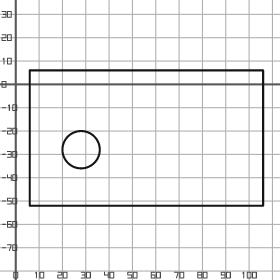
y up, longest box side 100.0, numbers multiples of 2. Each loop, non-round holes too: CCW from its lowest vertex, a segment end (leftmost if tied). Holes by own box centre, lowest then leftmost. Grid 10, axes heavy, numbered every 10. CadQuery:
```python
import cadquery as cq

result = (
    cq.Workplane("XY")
    .moveTo(6.0, -52.0)
    .lineTo(106.0, -52.0)
    .lineTo(106.0, 6.0)
    .lineTo(6.0, 6.0)
    .close()
    .moveTo(28.0, -28.0)
    .circle(8.0)
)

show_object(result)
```